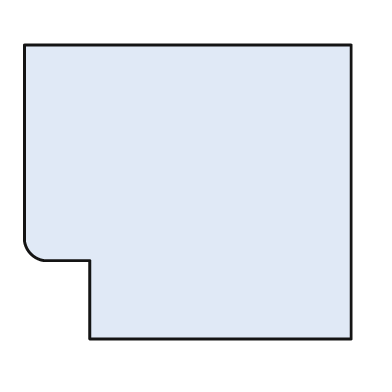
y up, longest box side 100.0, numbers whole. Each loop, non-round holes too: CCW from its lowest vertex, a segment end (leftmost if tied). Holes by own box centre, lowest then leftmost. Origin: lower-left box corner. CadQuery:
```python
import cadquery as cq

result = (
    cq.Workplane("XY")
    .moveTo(20.0, 0.0)
    .lineTo(100.0, 0.0)
    .lineTo(100.0, 90.0)
    .lineTo(0.0, 90.0)
    .lineTo(0.0, 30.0)
    .threePointArc((2.0, 26.0), (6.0, 24.0))
    .lineTo(20.0, 24.0)
    .close()
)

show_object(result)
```